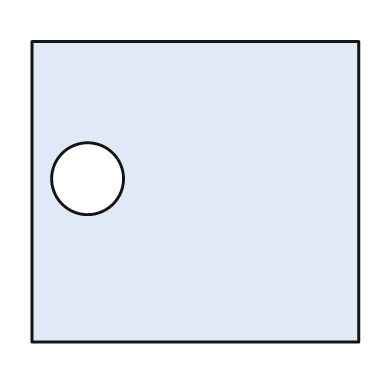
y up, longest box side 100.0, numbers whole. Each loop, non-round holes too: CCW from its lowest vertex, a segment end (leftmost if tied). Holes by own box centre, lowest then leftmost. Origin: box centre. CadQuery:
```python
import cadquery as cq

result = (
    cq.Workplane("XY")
    .moveTo(-50.0, -46.0)
    .lineTo(50.0, -46.0)
    .lineTo(50.0, 46.0)
    .lineTo(-50.0, 46.0)
    .close()
    .moveTo(-33.0, 4.0)
    .circle(11.0)
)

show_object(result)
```